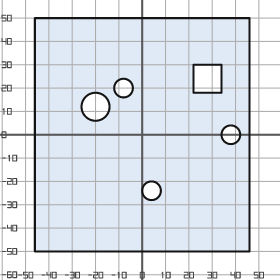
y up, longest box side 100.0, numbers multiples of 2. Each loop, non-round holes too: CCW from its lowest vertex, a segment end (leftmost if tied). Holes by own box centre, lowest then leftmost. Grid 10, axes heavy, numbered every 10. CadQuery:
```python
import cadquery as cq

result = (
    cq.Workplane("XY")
    .moveTo(-46.0, -50.0)
    .lineTo(46.0, -50.0)
    .lineTo(46.0, 50.0)
    .lineTo(-46.0, 50.0)
    .close()
    .moveTo(4.0, -24.0)
    .circle(4.0)
    .moveTo(38.0, 0.0)
    .circle(4.0)
    .moveTo(-20.0, 12.0)
    .circle(6.0)
    .moveTo(-8.0, 20.0)
    .circle(4.0)
    .moveTo(22.0, 18.0)
    .lineTo(34.0, 18.0)
    .lineTo(34.0, 30.0)
    .lineTo(22.0, 30.0)
    .close()
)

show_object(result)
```